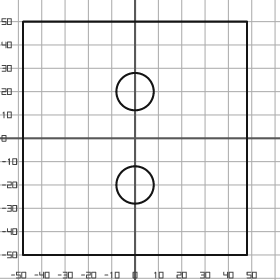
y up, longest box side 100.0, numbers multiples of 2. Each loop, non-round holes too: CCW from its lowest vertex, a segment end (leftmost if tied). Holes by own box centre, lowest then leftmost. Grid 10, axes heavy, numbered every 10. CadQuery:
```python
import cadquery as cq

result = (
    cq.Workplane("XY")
    .moveTo(-48.0, -50.0)
    .lineTo(48.0, -50.0)
    .lineTo(48.0, 50.0)
    .lineTo(-48.0, 50.0)
    .close()
    .moveTo(0.0, -20.0)
    .circle(8.0)
    .moveTo(0.0, 20.0)
    .circle(8.0)
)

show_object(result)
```